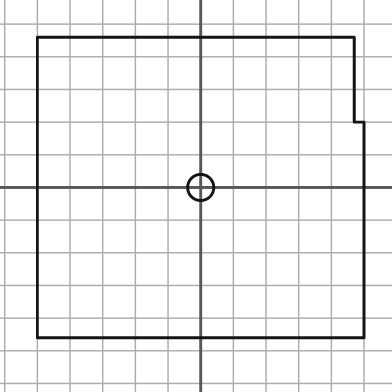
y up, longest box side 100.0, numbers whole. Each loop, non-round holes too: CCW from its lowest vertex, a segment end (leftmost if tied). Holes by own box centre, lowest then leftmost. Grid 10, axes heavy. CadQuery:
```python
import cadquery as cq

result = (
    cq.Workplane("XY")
    .moveTo(-50.0, -46.0)
    .lineTo(50.0, -46.0)
    .lineTo(50.0, 20.0)
    .lineTo(47.0, 20.0)
    .lineTo(47.0, 46.0)
    .lineTo(-50.0, 46.0)
    .close()
    .moveTo(0.0, 0.0)
    .circle(4.0)
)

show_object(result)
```